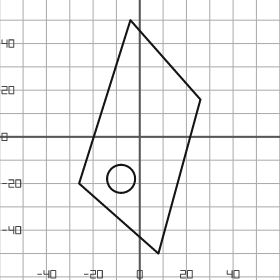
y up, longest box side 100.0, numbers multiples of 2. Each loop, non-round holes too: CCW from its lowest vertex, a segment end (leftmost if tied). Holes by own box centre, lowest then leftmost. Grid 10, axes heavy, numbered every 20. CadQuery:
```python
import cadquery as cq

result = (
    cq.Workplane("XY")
    .moveTo(8.0, -50.0)
    .lineTo(26.0, 16.0)
    .lineTo(-4.0, 50.0)
    .lineTo(-26.0, -20.0)
    .close()
    .moveTo(-8.0, -18.0)
    .circle(6.0)
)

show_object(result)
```